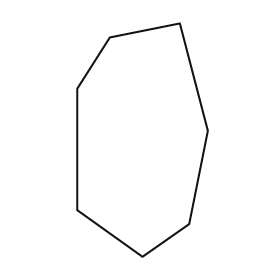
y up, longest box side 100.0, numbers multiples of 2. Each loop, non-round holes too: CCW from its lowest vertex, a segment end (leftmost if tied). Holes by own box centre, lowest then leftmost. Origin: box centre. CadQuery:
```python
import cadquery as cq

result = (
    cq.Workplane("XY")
    .moveTo(0.0, -50.0)
    .lineTo(20.0, -36.0)
    .lineTo(28.0, 4.0)
    .lineTo(16.0, 50.0)
    .lineTo(-14.0, 44.0)
    .lineTo(-28.0, 22.0)
    .lineTo(-28.0, -30.0)
    .close()
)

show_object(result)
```